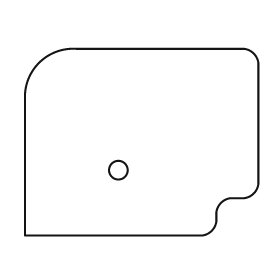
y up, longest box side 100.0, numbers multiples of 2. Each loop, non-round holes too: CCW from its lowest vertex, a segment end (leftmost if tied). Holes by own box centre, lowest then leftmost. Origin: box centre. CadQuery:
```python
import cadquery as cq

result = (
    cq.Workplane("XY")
    .moveTo(-50.0, -40.0)
    .lineTo(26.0, -40.0)
    .threePointArc((30.0, -38.0), (32.0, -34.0))
    .lineTo(32.0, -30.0)
    .threePointArc((34.0, -26.0), (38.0, -24.0))
    .lineTo(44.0, -24.0)
    .threePointArc((48.0, -22.0), (50.0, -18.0))
    .lineTo(50.0, 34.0)
    .threePointArc((48.0, 38.0), (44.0, 40.0))
    .lineTo(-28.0, 40.0)
    .threePointArc((-44.0, 34.0), (-50.0, 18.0))
    .close()
    .moveTo(-10.0, -12.0)
    .circle(4.0)
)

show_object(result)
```